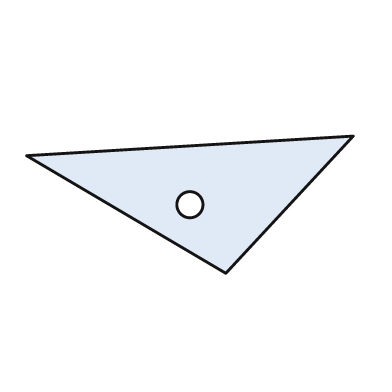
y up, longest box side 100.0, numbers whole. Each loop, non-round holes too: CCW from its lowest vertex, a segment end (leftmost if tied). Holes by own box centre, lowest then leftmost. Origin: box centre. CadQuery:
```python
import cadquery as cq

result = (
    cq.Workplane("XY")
    .moveTo(11.0, -21.0)
    .lineTo(50.0, 21.0)
    .lineTo(-50.0, 15.0)
    .close()
    .moveTo(0.0, 0.0)
    .circle(4.0)
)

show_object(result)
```